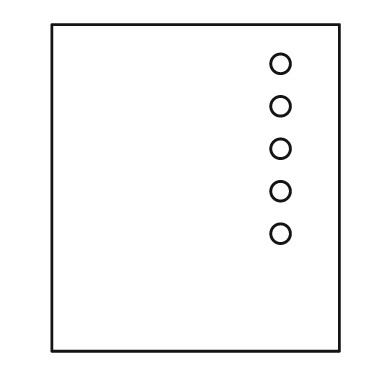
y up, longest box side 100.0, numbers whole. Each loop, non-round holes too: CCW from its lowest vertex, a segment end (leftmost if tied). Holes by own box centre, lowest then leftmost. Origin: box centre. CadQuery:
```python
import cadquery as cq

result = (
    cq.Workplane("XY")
    .moveTo(-44.0, -50.0)
    .lineTo(44.0, -50.0)
    .lineTo(44.0, 50.0)
    .lineTo(-44.0, 50.0)
    .close()
    .moveTo(26.0, -14.0)
    .circle(3.0)
    .moveTo(26.0, -1.0)
    .circle(3.0)
    .moveTo(26.0, 12.0)
    .circle(3.0)
    .moveTo(26.0, 25.0)
    .circle(3.0)
    .moveTo(26.0, 38.0)
    .circle(3.0)
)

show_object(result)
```